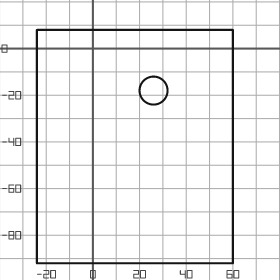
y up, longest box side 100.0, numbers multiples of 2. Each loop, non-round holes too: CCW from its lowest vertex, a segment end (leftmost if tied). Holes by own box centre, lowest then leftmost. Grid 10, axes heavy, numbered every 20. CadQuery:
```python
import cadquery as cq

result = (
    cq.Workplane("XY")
    .moveTo(-24.0, -92.0)
    .lineTo(60.0, -92.0)
    .lineTo(60.0, 8.0)
    .lineTo(-24.0, 8.0)
    .close()
    .moveTo(26.0, -18.0)
    .circle(6.0)
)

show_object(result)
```